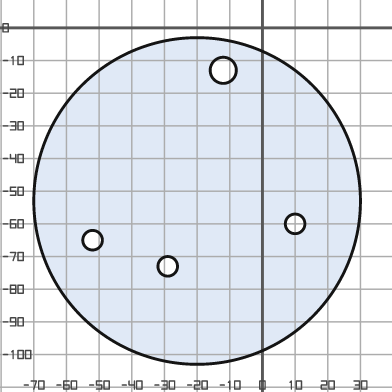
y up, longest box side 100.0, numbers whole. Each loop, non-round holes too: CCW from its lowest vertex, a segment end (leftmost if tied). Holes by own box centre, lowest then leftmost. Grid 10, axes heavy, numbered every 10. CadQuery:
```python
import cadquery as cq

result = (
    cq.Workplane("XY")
    .moveTo(-20.0, -53.0)
    .circle(50.0)
    .moveTo(-29.0, -73.0)
    .circle(3.0)
    .moveTo(-52.0, -65.0)
    .circle(3.0)
    .moveTo(10.0, -60.0)
    .circle(3.0)
    .moveTo(-12.0, -13.0)
    .circle(4.0)
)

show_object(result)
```